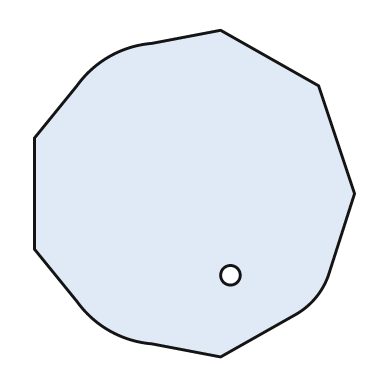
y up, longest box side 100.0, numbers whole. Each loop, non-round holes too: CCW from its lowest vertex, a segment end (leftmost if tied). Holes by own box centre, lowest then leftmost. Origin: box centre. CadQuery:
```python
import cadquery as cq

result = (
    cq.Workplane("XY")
    .moveTo(8.0, -50.0)
    .lineTo(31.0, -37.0)
    .threePointArc((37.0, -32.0), (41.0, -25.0))
    .lineTo(49.0, 0.0)
    .lineTo(38.0, 33.0)
    .lineTo(8.0, 50.0)
    .lineTo(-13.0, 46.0)
    .threePointArc((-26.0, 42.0), (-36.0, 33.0))
    .lineTo(-49.0, 17.0)
    .lineTo(-49.0, -17.0)
    .lineTo(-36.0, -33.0)
    .threePointArc((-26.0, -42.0), (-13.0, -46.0))
    .close()
    .moveTo(11.0, -25.0)
    .circle(3.0)
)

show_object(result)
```